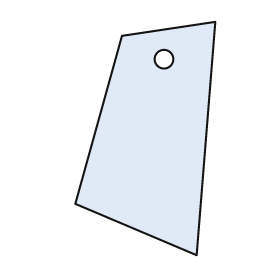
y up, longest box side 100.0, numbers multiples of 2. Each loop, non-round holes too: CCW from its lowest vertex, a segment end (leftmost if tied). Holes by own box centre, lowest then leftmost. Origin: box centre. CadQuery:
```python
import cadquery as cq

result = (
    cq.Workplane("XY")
    .moveTo(22.0, -50.0)
    .lineTo(30.0, 50.0)
    .lineTo(-10.0, 44.0)
    .lineTo(-30.0, -28.0)
    .close()
    .moveTo(8.0, 34.0)
    .circle(4.0)
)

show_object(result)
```